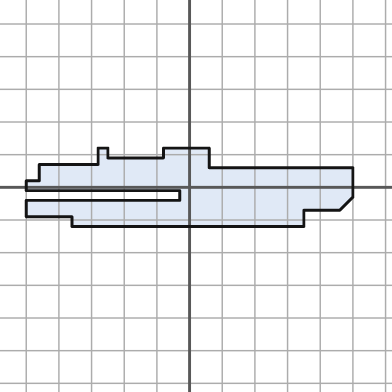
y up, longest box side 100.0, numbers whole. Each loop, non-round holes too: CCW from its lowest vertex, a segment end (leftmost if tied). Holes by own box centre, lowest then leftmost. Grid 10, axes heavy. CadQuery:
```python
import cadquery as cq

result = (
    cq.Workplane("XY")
    .moveTo(-36.0, -12.0)
    .lineTo(35.0, -12.0)
    .lineTo(35.0, -7.0)
    .lineTo(46.0, -7.0)
    .lineTo(50.0, -3.0)
    .lineTo(50.0, 6.0)
    .lineTo(6.0, 6.0)
    .lineTo(6.0, 12.0)
    .lineTo(-8.0, 12.0)
    .lineTo(-8.0, 9.0)
    .lineTo(-25.0, 9.0)
    .lineTo(-25.0, 12.0)
    .lineTo(-28.0, 12.0)
    .lineTo(-28.0, 7.0)
    .lineTo(-46.0, 7.0)
    .lineTo(-46.0, 2.0)
    .lineTo(-50.0, 2.0)
    .lineTo(-50.0, -1.0)
    .lineTo(-3.0, -1.0)
    .lineTo(-3.0, -4.0)
    .lineTo(-50.0, -4.0)
    .lineTo(-50.0, -9.0)
    .lineTo(-36.0, -9.0)
    .close()
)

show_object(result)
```